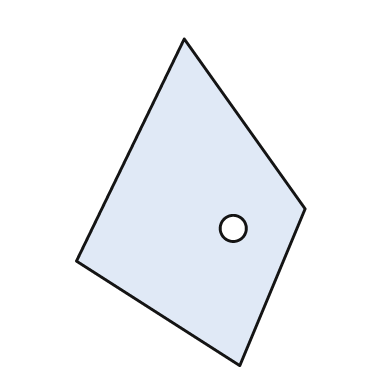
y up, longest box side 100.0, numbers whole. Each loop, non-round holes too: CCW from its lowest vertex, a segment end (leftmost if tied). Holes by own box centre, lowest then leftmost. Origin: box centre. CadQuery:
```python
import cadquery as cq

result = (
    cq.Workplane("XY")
    .moveTo(15.0, -50.0)
    .lineTo(35.0, -2.0)
    .lineTo(-2.0, 50.0)
    .lineTo(-35.0, -18.0)
    .close()
    .moveTo(13.0, -8.0)
    .circle(4.0)
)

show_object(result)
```